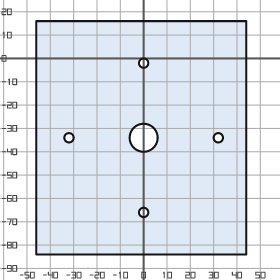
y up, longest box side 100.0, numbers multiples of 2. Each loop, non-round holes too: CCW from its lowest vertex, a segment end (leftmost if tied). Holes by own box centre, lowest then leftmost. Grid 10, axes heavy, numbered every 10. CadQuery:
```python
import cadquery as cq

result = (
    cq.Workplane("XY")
    .moveTo(-46.0, -84.0)
    .lineTo(44.0, -84.0)
    .lineTo(44.0, 16.0)
    .lineTo(-46.0, 16.0)
    .close()
    .moveTo(0.0, -66.0)
    .circle(2.0)
    .moveTo(-32.0, -34.0)
    .circle(2.0)
    .moveTo(0.0, -34.0)
    .circle(6.0)
    .moveTo(32.0, -34.0)
    .circle(2.0)
    .moveTo(0.0, -2.0)
    .circle(2.0)
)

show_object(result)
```